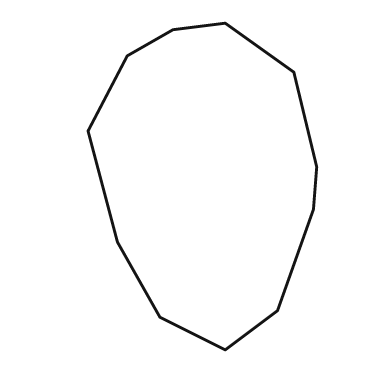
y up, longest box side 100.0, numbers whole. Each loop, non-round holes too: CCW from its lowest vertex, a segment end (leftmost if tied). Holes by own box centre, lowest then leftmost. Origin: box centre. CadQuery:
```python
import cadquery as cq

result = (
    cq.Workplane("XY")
    .moveTo(7.0, -50.0)
    .lineTo(23.0, -38.0)
    .lineTo(34.0, -7.0)
    .lineTo(35.0, 6.0)
    .lineTo(28.0, 35.0)
    .lineTo(7.0, 50.0)
    .lineTo(-9.0, 48.0)
    .lineTo(-23.0, 40.0)
    .lineTo(-35.0, 17.0)
    .lineTo(-26.0, -17.0)
    .lineTo(-13.0, -40.0)
    .close()
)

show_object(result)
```